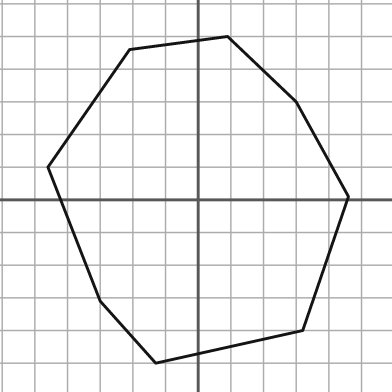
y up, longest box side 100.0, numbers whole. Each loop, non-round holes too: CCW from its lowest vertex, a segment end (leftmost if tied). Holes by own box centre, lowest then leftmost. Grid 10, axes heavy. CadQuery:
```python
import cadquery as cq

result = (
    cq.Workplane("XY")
    .moveTo(-13.0, -50.0)
    .lineTo(32.0, -40.0)
    .lineTo(46.0, 1.0)
    .lineTo(30.0, 30.0)
    .lineTo(9.0, 50.0)
    .lineTo(-21.0, 46.0)
    .lineTo(-46.0, 10.0)
    .lineTo(-30.0, -31.0)
    .close()
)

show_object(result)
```